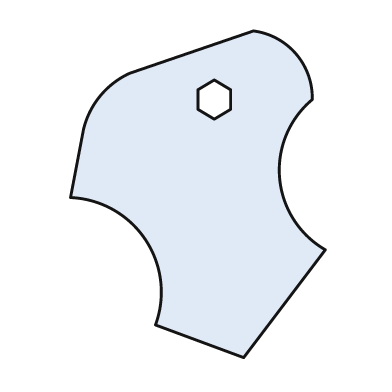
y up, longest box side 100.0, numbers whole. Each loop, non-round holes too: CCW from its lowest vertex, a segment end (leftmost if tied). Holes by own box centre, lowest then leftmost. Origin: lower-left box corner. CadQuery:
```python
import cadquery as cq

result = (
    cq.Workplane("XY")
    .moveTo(53.0, 0.0)
    .lineTo(78.0, 33.0)
    .threePointArc((64.0, 55.0), (74.0, 79.0))
    .threePointArc((69.0, 93.0), (56.0, 100.0))
    .lineTo(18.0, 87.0)
    .threePointArc((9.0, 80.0), (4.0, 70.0))
    .lineTo(0.0, 49.0)
    .threePointArc((23.0, 36.0), (26.0, 10.0))
    .close()
    .moveTo(44.0, 73.0)
    .lineTo(49.0, 76.0)
    .lineTo(49.0, 82.0)
    .lineTo(44.0, 85.0)
    .lineTo(39.0, 82.0)
    .lineTo(39.0, 76.0)
    .close()
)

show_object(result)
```